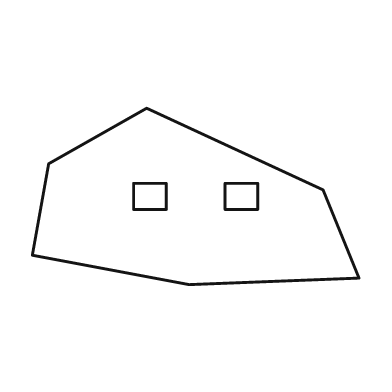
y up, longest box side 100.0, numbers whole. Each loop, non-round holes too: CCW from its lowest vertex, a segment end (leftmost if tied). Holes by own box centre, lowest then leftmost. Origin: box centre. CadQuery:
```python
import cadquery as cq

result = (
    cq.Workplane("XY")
    .moveTo(-2.0, -27.0)
    .lineTo(50.0, -25.0)
    .lineTo(39.0, 2.0)
    .lineTo(-15.0, 27.0)
    .lineTo(-45.0, 10.0)
    .lineTo(-50.0, -18.0)
    .close()
    .moveTo(-19.0, -4.0)
    .lineTo(-9.0, -4.0)
    .lineTo(-9.0, 4.0)
    .lineTo(-19.0, 4.0)
    .close()
    .moveTo(9.0, -4.0)
    .lineTo(19.0, -4.0)
    .lineTo(19.0, 4.0)
    .lineTo(9.0, 4.0)
    .close()
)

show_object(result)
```